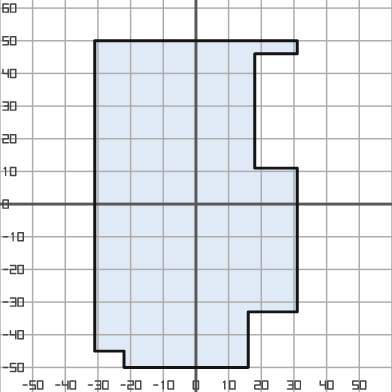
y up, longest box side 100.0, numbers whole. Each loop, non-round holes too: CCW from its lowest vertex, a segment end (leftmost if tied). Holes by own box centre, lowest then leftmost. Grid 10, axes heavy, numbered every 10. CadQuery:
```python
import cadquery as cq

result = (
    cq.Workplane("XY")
    .moveTo(-22.0, -50.0)
    .lineTo(16.0, -50.0)
    .lineTo(16.0, -33.0)
    .lineTo(31.0, -33.0)
    .lineTo(31.0, 11.0)
    .lineTo(18.0, 11.0)
    .lineTo(18.0, 46.0)
    .lineTo(31.0, 46.0)
    .lineTo(31.0, 50.0)
    .lineTo(-31.0, 50.0)
    .lineTo(-31.0, -45.0)
    .lineTo(-22.0, -45.0)
    .close()
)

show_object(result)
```